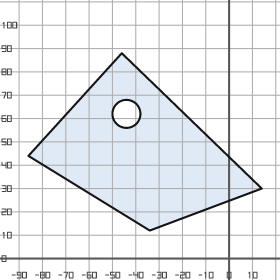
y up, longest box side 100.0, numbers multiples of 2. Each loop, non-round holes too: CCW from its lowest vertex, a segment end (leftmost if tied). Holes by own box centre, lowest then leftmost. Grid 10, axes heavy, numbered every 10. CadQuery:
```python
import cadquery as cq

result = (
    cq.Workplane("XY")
    .moveTo(-34.0, 12.0)
    .lineTo(14.0, 30.0)
    .lineTo(-46.0, 88.0)
    .lineTo(-86.0, 44.0)
    .close()
    .moveTo(-44.0, 62.0)
    .circle(6.0)
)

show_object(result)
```